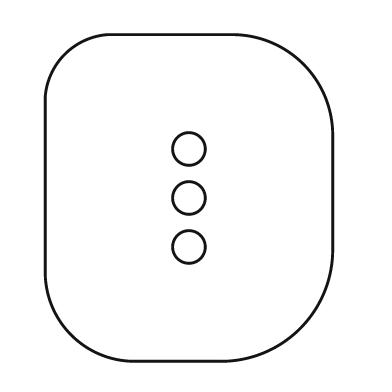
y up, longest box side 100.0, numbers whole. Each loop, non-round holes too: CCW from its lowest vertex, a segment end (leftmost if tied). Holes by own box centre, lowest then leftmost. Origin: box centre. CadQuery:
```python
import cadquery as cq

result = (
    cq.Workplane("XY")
    .moveTo(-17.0, -50.0)
    .lineTo(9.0, -50.0)
    .threePointArc((34.0, -40.0), (44.0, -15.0))
    .lineTo(44.0, 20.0)
    .threePointArc((35.0, 41.0), (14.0, 50.0))
    .lineTo(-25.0, 50.0)
    .threePointArc((-38.0, 44.0), (-44.0, 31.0))
    .lineTo(-44.0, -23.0)
    .threePointArc((-36.0, -42.0), (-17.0, -50.0))
    .close()
    .moveTo(0.0, -15.0)
    .circle(5.0)
    .moveTo(0.0, 0.0)
    .circle(5.0)
    .moveTo(0.0, 15.0)
    .circle(5.0)
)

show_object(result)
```